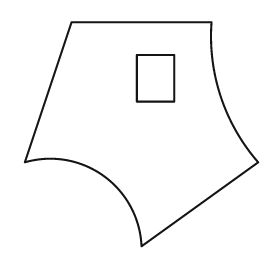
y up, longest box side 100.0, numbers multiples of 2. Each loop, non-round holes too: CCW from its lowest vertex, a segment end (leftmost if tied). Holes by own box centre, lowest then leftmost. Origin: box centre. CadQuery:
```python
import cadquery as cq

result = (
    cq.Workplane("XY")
    .moveTo(0.0, -48.0)
    .lineTo(50.0, -12.0)
    .threePointArc((34.0, 16.0), (30.0, 48.0))
    .lineTo(-30.0, 48.0)
    .lineTo(-50.0, -12.0)
    .threePointArc((-16.0, -18.0), (0.0, -48.0))
    .close()
    .moveTo(-2.0, 14.0)
    .lineTo(14.0, 14.0)
    .lineTo(14.0, 34.0)
    .lineTo(-2.0, 34.0)
    .close()
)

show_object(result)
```